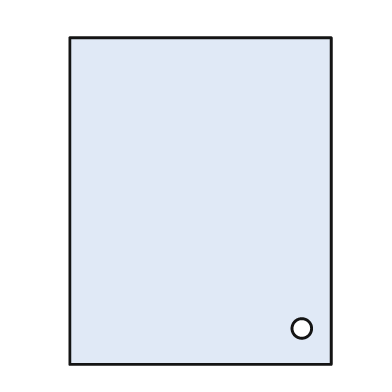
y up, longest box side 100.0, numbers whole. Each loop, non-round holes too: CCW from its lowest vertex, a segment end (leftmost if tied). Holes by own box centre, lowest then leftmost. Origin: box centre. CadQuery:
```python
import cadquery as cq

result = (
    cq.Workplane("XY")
    .moveTo(-40.0, -50.0)
    .lineTo(40.0, -50.0)
    .lineTo(40.0, 50.0)
    .lineTo(-40.0, 50.0)
    .close()
    .moveTo(31.0, -39.0)
    .circle(3.0)
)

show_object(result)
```